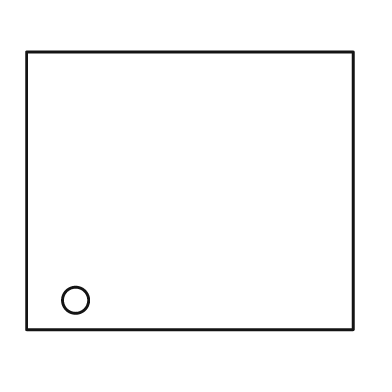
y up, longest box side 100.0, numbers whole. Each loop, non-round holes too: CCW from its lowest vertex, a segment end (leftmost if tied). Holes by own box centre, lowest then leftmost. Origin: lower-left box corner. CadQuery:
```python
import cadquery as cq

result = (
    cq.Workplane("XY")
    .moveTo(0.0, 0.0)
    .lineTo(100.0, 0.0)
    .lineTo(100.0, 85.0)
    .lineTo(0.0, 85.0)
    .close()
    .moveTo(15.0, 9.0)
    .circle(4.0)
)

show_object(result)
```